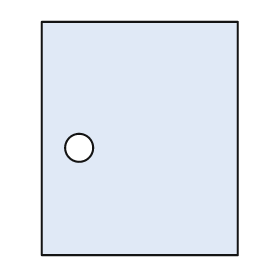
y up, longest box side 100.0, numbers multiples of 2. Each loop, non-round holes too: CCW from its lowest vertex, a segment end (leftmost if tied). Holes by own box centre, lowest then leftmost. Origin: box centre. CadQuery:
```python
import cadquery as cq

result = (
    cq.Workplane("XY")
    .moveTo(-42.0, -50.0)
    .lineTo(42.0, -50.0)
    .lineTo(42.0, 50.0)
    .lineTo(-42.0, 50.0)
    .close()
    .moveTo(-26.0, -4.0)
    .circle(6.0)
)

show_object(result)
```